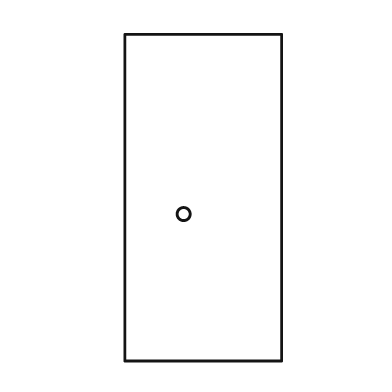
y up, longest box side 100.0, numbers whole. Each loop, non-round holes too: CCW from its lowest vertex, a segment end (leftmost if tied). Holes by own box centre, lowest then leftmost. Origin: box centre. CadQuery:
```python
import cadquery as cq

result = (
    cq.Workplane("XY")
    .moveTo(-24.0, -50.0)
    .lineTo(24.0, -50.0)
    .lineTo(24.0, 50.0)
    .lineTo(-24.0, 50.0)
    .close()
    .moveTo(-6.0, -5.0)
    .circle(2.0)
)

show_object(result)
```